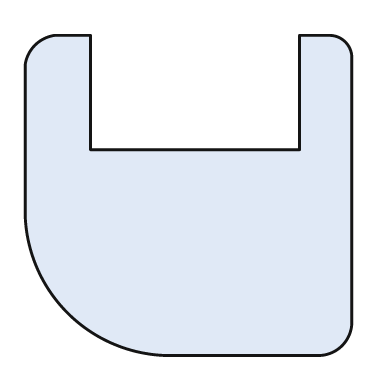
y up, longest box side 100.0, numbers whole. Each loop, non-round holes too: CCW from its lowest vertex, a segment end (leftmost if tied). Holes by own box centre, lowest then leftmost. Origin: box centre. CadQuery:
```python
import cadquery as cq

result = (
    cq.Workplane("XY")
    .moveTo(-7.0, -49.0)
    .lineTo(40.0, -49.0)
    .threePointArc((47.0, -46.0), (50.0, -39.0))
    .lineTo(50.0, 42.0)
    .threePointArc((48.0, 47.0), (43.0, 49.0))
    .lineTo(34.0, 49.0)
    .lineTo(34.0, 14.0)
    .lineTo(-30.0, 14.0)
    .lineTo(-30.0, 49.0)
    .lineTo(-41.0, 49.0)
    .threePointArc((-47.0, 46.0), (-50.0, 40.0))
    .lineTo(-50.0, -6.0)
    .threePointArc((-37.0, -36.0), (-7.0, -49.0))
    .close()
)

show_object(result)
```